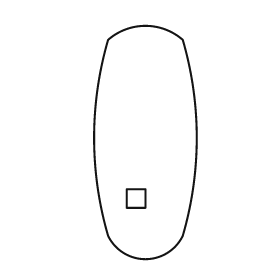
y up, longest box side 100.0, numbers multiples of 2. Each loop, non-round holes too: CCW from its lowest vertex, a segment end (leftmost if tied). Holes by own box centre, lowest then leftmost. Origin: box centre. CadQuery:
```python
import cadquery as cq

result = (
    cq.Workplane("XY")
    .moveTo(-16.0, -40.0)
    .threePointArc((0.0, -50.0), (16.0, -40.0))
    .threePointArc((22.0, 2.0), (16.0, 44.0))
    .threePointArc((0.0, 50.0), (-16.0, 44.0))
    .threePointArc((-22.0, 2.0), (-16.0, -40.0))
    .close()
    .moveTo(-8.0, -28.0)
    .lineTo(0.0, -28.0)
    .lineTo(0.0, -20.0)
    .lineTo(-8.0, -20.0)
    .close()
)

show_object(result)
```